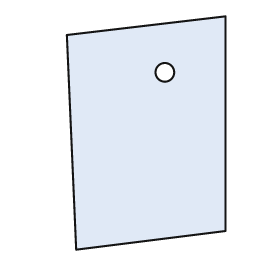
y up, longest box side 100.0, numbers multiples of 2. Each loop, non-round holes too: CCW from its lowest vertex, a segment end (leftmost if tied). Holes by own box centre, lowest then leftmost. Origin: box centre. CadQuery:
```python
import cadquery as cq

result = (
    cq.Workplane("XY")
    .moveTo(-30.0, -50.0)
    .lineTo(34.0, -42.0)
    .lineTo(34.0, 50.0)
    .lineTo(-34.0, 42.0)
    .close()
    .moveTo(8.0, 26.0)
    .circle(4.0)
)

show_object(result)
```